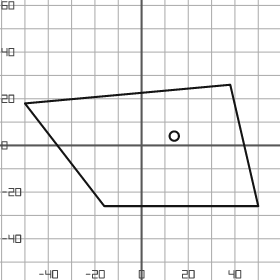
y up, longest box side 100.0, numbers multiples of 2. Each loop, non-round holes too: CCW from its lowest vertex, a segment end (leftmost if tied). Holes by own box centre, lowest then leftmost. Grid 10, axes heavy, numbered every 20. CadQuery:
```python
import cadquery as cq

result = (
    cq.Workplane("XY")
    .moveTo(-16.0, -26.0)
    .lineTo(50.0, -26.0)
    .lineTo(38.0, 26.0)
    .lineTo(-50.0, 18.0)
    .close()
    .moveTo(14.0, 4.0)
    .circle(2.0)
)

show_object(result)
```